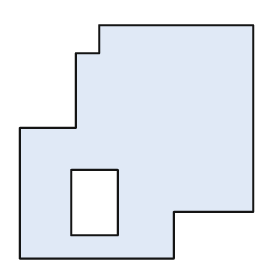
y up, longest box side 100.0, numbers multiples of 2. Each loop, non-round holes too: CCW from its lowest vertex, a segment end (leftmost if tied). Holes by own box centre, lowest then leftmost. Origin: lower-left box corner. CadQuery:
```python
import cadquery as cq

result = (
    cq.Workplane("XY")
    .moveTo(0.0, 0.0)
    .lineTo(66.0, 0.0)
    .lineTo(66.0, 20.0)
    .lineTo(100.0, 20.0)
    .lineTo(100.0, 100.0)
    .lineTo(34.0, 100.0)
    .lineTo(34.0, 88.0)
    .lineTo(24.0, 88.0)
    .lineTo(24.0, 56.0)
    .lineTo(0.0, 56.0)
    .close()
    .moveTo(22.0, 10.0)
    .lineTo(42.0, 10.0)
    .lineTo(42.0, 38.0)
    .lineTo(22.0, 38.0)
    .close()
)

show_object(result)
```